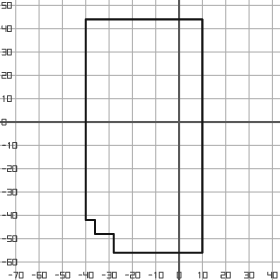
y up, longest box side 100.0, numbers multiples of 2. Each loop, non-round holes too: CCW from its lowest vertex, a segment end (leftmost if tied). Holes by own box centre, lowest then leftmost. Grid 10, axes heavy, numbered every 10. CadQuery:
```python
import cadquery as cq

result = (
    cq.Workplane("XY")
    .moveTo(-28.0, -56.0)
    .lineTo(10.0, -56.0)
    .lineTo(10.0, 44.0)
    .lineTo(-40.0, 44.0)
    .lineTo(-40.0, -42.0)
    .lineTo(-36.0, -42.0)
    .lineTo(-36.0, -48.0)
    .lineTo(-28.0, -48.0)
    .close()
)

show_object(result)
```